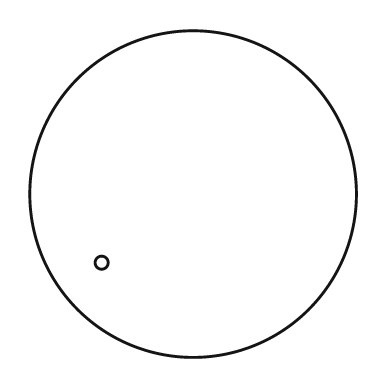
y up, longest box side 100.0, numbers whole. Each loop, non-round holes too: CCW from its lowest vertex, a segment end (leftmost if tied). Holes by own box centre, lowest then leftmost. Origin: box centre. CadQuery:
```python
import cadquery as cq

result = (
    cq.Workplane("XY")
    .moveTo(0.0, 0.0)
    .circle(50.0)
    .moveTo(-28.0, -21.0)
    .circle(2.0)
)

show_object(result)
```